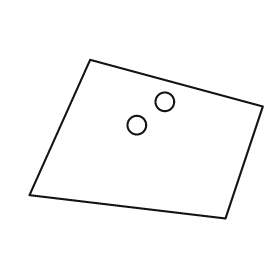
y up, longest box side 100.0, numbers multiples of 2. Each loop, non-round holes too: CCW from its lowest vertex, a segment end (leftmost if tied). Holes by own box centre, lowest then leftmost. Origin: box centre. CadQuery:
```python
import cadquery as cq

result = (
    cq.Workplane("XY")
    .moveTo(34.0, -34.0)
    .lineTo(50.0, 14.0)
    .lineTo(-24.0, 34.0)
    .lineTo(-50.0, -24.0)
    .close()
    .moveTo(-4.0, 6.0)
    .circle(4.0)
    .moveTo(8.0, 16.0)
    .circle(4.0)
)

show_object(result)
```